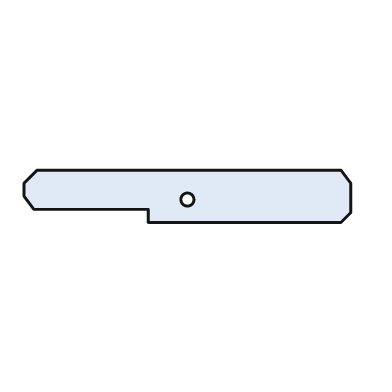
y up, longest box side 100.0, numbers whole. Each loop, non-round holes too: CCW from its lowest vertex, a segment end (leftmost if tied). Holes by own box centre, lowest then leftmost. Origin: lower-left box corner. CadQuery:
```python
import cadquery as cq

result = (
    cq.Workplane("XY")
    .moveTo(38.0, 0.0)
    .lineTo(97.0, 0.0)
    .lineTo(100.0, 3.0)
    .lineTo(100.0, 12.0)
    .lineTo(97.0, 16.0)
    .lineTo(4.0, 16.0)
    .lineTo(0.0, 12.0)
    .lineTo(0.0, 8.0)
    .lineTo(3.0, 4.0)
    .lineTo(38.0, 4.0)
    .close()
    .moveTo(50.0, 7.0)
    .circle(2.0)
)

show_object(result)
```